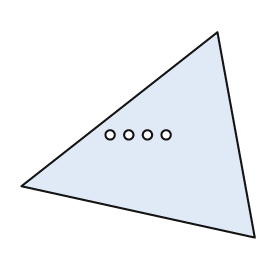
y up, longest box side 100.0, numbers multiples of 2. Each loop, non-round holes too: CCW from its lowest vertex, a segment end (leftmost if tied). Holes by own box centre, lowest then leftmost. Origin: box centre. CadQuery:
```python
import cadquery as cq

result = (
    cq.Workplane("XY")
    .moveTo(50.0, -44.0)
    .lineTo(34.0, 44.0)
    .lineTo(-50.0, -22.0)
    .close()
    .moveTo(-12.0, 0.0)
    .circle(2.0)
    .moveTo(-4.0, 0.0)
    .circle(2.0)
    .moveTo(4.0, 0.0)
    .circle(2.0)
    .moveTo(12.0, 0.0)
    .circle(2.0)
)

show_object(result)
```